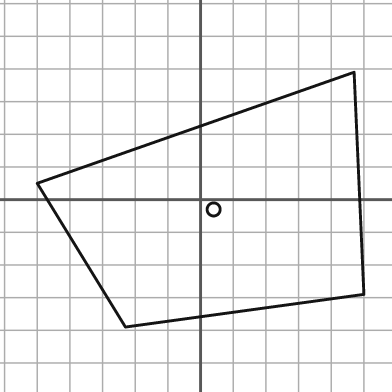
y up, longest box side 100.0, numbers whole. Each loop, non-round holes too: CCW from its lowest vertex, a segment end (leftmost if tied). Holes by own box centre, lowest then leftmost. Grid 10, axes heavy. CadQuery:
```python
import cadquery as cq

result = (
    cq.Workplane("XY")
    .moveTo(-23.0, -39.0)
    .lineTo(50.0, -29.0)
    .lineTo(47.0, 39.0)
    .lineTo(-50.0, 5.0)
    .close()
    .moveTo(4.0, -3.0)
    .circle(2.0)
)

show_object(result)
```